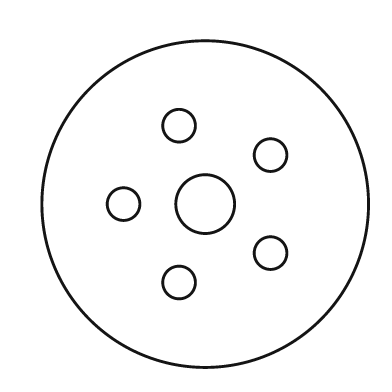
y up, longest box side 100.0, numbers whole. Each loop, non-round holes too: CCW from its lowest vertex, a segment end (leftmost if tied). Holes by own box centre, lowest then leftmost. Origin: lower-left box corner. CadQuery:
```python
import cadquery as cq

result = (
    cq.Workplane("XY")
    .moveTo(50.0, 50.0)
    .circle(50.0)
    .moveTo(42.0, 26.0)
    .circle(5.0)
    .moveTo(70.0, 35.0)
    .circle(5.0)
    .moveTo(25.0, 50.0)
    .circle(5.0)
    .moveTo(50.0, 50.0)
    .circle(9.0)
    .moveTo(70.0, 65.0)
    .circle(5.0)
    .moveTo(42.0, 74.0)
    .circle(5.0)
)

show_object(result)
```